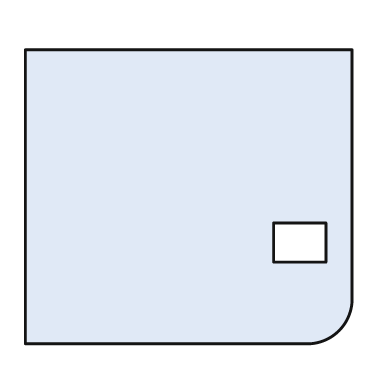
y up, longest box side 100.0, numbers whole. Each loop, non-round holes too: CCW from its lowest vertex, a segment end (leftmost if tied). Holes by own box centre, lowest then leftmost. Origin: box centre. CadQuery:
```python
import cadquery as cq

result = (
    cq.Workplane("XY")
    .moveTo(-50.0, -45.0)
    .lineTo(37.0, -45.0)
    .threePointArc((46.0, -41.0), (50.0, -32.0))
    .lineTo(50.0, 45.0)
    .lineTo(-50.0, 45.0)
    .close()
    .moveTo(26.0, -20.0)
    .lineTo(42.0, -20.0)
    .lineTo(42.0, -8.0)
    .lineTo(26.0, -8.0)
    .close()
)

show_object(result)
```